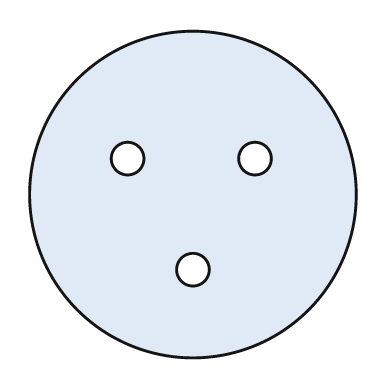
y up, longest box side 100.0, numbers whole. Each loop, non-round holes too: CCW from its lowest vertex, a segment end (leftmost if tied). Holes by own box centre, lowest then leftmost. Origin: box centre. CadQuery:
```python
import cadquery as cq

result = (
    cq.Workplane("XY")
    .moveTo(0.0, 0.0)
    .circle(50.0)
    .moveTo(0.0, -23.0)
    .circle(5.0)
    .moveTo(-20.0, 11.0)
    .circle(5.0)
    .moveTo(19.0, 11.0)
    .circle(5.0)
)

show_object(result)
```